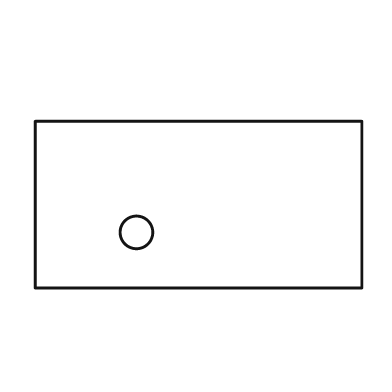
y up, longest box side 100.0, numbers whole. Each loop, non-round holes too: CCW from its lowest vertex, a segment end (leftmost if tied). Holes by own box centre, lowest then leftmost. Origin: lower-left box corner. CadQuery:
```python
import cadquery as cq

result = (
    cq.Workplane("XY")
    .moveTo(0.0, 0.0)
    .lineTo(100.0, 0.0)
    .lineTo(100.0, 51.0)
    .lineTo(0.0, 51.0)
    .close()
    .moveTo(31.0, 17.0)
    .circle(5.0)
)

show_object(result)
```